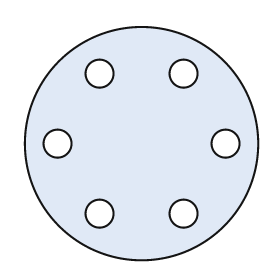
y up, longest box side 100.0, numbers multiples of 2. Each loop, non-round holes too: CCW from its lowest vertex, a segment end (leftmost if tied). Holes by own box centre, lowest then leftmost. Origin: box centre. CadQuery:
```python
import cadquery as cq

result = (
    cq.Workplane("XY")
    .moveTo(0.0, 0.0)
    .circle(50.0)
    .moveTo(-18.0, -30.0)
    .circle(6.0)
    .moveTo(18.0, -30.0)
    .circle(6.0)
    .moveTo(-36.0, 0.0)
    .circle(6.0)
    .moveTo(36.0, 0.0)
    .circle(6.0)
    .moveTo(-18.0, 30.0)
    .circle(6.0)
    .moveTo(18.0, 30.0)
    .circle(6.0)
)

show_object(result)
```